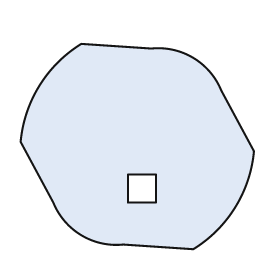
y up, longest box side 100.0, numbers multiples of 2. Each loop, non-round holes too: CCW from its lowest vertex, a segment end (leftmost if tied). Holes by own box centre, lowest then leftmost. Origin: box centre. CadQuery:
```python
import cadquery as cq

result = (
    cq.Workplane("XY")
    .moveTo(24.0, -44.0)
    .threePointArc((42.0, -26.0), (50.0, -2.0))
    .lineTo(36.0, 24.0)
    .threePointArc((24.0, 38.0), (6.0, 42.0))
    .lineTo(-24.0, 44.0)
    .threePointArc((-42.0, 26.0), (-50.0, 2.0))
    .lineTo(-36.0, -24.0)
    .threePointArc((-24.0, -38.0), (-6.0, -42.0))
    .close()
    .moveTo(-4.0, -24.0)
    .lineTo(8.0, -24.0)
    .lineTo(8.0, -12.0)
    .lineTo(-4.0, -12.0)
    .close()
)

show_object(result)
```